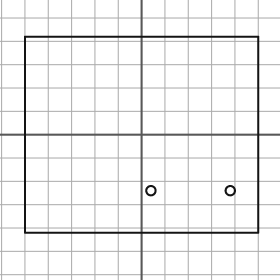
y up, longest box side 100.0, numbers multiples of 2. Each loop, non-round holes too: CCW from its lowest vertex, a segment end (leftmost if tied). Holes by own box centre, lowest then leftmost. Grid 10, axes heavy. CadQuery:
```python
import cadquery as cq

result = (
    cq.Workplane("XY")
    .moveTo(-50.0, -42.0)
    .lineTo(50.0, -42.0)
    .lineTo(50.0, 42.0)
    .lineTo(-50.0, 42.0)
    .close()
    .moveTo(4.0, -24.0)
    .circle(2.0)
    .moveTo(38.0, -24.0)
    .circle(2.0)
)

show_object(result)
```